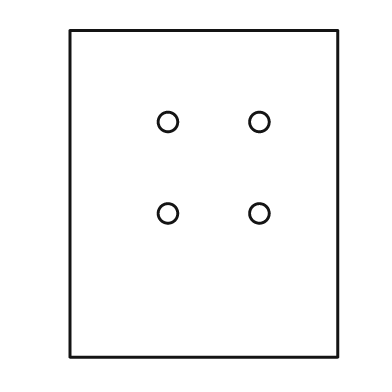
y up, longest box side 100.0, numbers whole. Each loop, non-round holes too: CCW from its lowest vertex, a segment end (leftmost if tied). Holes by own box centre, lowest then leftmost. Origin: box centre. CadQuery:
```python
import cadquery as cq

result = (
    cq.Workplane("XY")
    .moveTo(-41.0, -50.0)
    .lineTo(41.0, -50.0)
    .lineTo(41.0, 50.0)
    .lineTo(-41.0, 50.0)
    .close()
    .moveTo(-11.0, -6.0)
    .circle(3.0)
    .moveTo(17.0, -6.0)
    .circle(3.0)
    .moveTo(-11.0, 22.0)
    .circle(3.0)
    .moveTo(17.0, 22.0)
    .circle(3.0)
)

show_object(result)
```